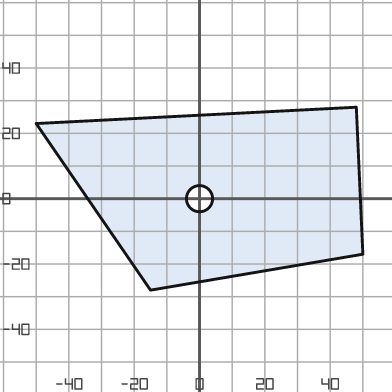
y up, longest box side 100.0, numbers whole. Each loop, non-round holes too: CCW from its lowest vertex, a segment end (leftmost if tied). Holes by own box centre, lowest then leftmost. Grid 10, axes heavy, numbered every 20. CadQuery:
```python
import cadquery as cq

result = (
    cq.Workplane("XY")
    .moveTo(-15.0, -28.0)
    .lineTo(50.0, -17.0)
    .lineTo(48.0, 28.0)
    .lineTo(-50.0, 23.0)
    .close()
    .moveTo(0.0, 0.0)
    .circle(4.0)
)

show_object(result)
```